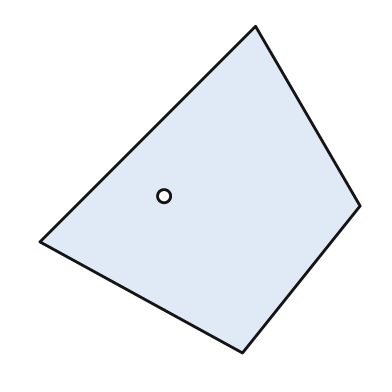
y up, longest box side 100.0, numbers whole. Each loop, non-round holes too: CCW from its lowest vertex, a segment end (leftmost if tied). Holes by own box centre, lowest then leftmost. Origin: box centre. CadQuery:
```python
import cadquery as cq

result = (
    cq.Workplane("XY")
    .moveTo(13.0, -50.0)
    .lineTo(49.0, -5.0)
    .lineTo(17.0, 50.0)
    .lineTo(-49.0, -16.0)
    .close()
    .moveTo(-11.0, -2.0)
    .circle(2.0)
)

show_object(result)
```